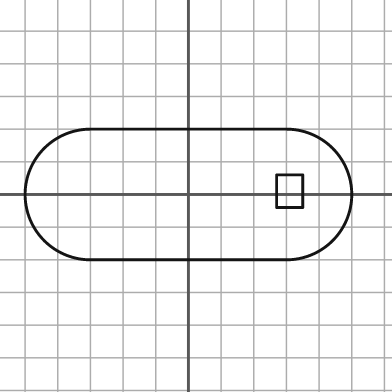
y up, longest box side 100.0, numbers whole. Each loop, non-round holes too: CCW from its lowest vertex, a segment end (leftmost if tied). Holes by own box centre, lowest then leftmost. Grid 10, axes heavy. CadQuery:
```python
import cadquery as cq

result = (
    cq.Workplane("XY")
    .moveTo(-30.0, -20.0)
    .lineTo(30.0, -20.0)
    .threePointArc((50.0, 0.0), (30.0, 20.0))
    .lineTo(-30.0, 20.0)
    .threePointArc((-50.0, 0.0), (-30.0, -20.0))
    .close()
    .moveTo(27.0, -4.0)
    .lineTo(35.0, -4.0)
    .lineTo(35.0, 6.0)
    .lineTo(27.0, 6.0)
    .close()
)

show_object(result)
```